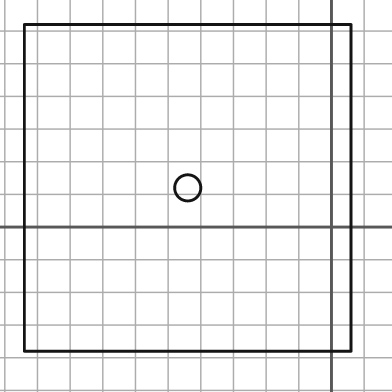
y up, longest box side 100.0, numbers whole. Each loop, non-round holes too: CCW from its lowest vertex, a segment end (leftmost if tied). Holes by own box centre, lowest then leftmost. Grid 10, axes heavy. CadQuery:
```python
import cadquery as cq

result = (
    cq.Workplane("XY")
    .moveTo(-94.0, -38.0)
    .lineTo(6.0, -38.0)
    .lineTo(6.0, 62.0)
    .lineTo(-94.0, 62.0)
    .close()
    .moveTo(-44.0, 12.0)
    .circle(4.0)
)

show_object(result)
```